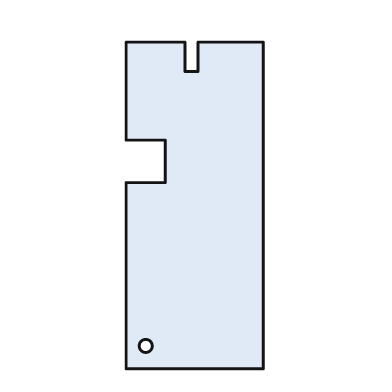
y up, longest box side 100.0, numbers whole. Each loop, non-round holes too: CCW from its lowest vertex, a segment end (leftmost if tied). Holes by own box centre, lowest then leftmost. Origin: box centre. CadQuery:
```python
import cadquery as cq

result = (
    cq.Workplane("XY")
    .moveTo(-21.0, -50.0)
    .lineTo(21.0, -50.0)
    .lineTo(21.0, 50.0)
    .lineTo(1.0, 50.0)
    .lineTo(1.0, 41.0)
    .lineTo(-3.0, 41.0)
    .lineTo(-3.0, 50.0)
    .lineTo(-21.0, 50.0)
    .lineTo(-21.0, 20.0)
    .lineTo(-9.0, 20.0)
    .lineTo(-9.0, 7.0)
    .lineTo(-21.0, 7.0)
    .close()
    .moveTo(-15.0, -43.0)
    .circle(2.0)
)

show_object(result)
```